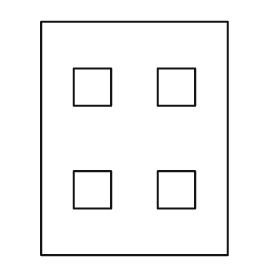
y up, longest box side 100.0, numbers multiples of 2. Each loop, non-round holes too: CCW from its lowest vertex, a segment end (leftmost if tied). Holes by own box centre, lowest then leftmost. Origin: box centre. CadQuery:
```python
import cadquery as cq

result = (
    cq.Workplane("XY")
    .moveTo(-40.0, -50.0)
    .lineTo(40.0, -50.0)
    .lineTo(40.0, 50.0)
    .lineTo(-40.0, 50.0)
    .close()
    .moveTo(-26.0, -30.0)
    .lineTo(-10.0, -30.0)
    .lineTo(-10.0, -14.0)
    .lineTo(-26.0, -14.0)
    .close()
    .moveTo(10.0, -30.0)
    .lineTo(26.0, -30.0)
    .lineTo(26.0, -14.0)
    .lineTo(10.0, -14.0)
    .close()
    .moveTo(-26.0, 14.0)
    .lineTo(-10.0, 14.0)
    .lineTo(-10.0, 30.0)
    .lineTo(-26.0, 30.0)
    .close()
    .moveTo(10.0, 14.0)
    .lineTo(26.0, 14.0)
    .lineTo(26.0, 30.0)
    .lineTo(10.0, 30.0)
    .close()
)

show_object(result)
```